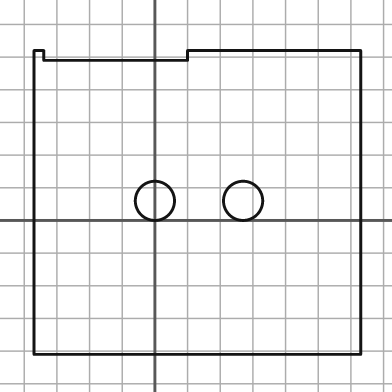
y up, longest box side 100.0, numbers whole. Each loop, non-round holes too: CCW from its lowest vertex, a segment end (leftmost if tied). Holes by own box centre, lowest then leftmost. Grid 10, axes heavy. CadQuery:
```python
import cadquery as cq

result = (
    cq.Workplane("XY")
    .moveTo(-37.0, -41.0)
    .lineTo(63.0, -41.0)
    .lineTo(63.0, 52.0)
    .lineTo(10.0, 52.0)
    .lineTo(10.0, 49.0)
    .lineTo(-34.0, 49.0)
    .lineTo(-34.0, 52.0)
    .lineTo(-37.0, 52.0)
    .close()
    .moveTo(0.0, 6.0)
    .circle(6.0)
    .moveTo(27.0, 6.0)
    .circle(6.0)
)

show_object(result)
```